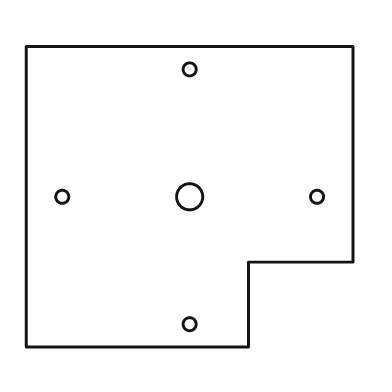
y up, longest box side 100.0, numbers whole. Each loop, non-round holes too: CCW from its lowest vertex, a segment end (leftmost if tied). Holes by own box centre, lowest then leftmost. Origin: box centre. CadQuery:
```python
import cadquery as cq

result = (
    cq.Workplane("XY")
    .moveTo(-50.0, -46.0)
    .lineTo(18.0, -46.0)
    .lineTo(18.0, -20.0)
    .lineTo(50.0, -20.0)
    .lineTo(50.0, 46.0)
    .lineTo(-50.0, 46.0)
    .close()
    .moveTo(0.0, -39.0)
    .circle(2.0)
    .moveTo(-39.0, 0.0)
    .circle(2.0)
    .moveTo(0.0, 0.0)
    .circle(4.0)
    .moveTo(39.0, 0.0)
    .circle(2.0)
    .moveTo(0.0, 39.0)
    .circle(2.0)
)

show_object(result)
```